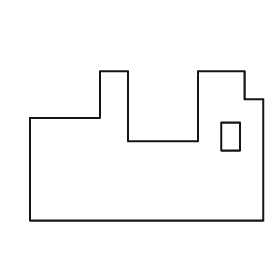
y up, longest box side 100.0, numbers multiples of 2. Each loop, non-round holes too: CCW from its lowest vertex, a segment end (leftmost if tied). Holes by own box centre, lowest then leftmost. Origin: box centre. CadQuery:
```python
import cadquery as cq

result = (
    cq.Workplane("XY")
    .moveTo(-50.0, -32.0)
    .lineTo(50.0, -32.0)
    .lineTo(50.0, 20.0)
    .lineTo(42.0, 20.0)
    .lineTo(42.0, 32.0)
    .lineTo(22.0, 32.0)
    .lineTo(22.0, 2.0)
    .lineTo(-8.0, 2.0)
    .lineTo(-8.0, 32.0)
    .lineTo(-20.0, 32.0)
    .lineTo(-20.0, 12.0)
    .lineTo(-50.0, 12.0)
    .close()
    .moveTo(32.0, -2.0)
    .lineTo(40.0, -2.0)
    .lineTo(40.0, 10.0)
    .lineTo(32.0, 10.0)
    .close()
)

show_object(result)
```